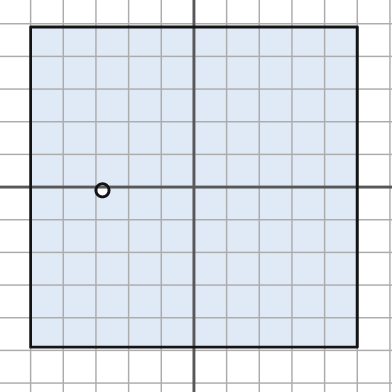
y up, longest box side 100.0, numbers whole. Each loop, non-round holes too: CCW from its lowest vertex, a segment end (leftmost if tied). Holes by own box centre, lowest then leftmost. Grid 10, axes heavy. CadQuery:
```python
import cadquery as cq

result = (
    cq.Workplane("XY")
    .moveTo(-50.0, -49.0)
    .lineTo(50.0, -49.0)
    .lineTo(50.0, 49.0)
    .lineTo(-50.0, 49.0)
    .close()
    .moveTo(-28.0, -1.0)
    .circle(2.0)
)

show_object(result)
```